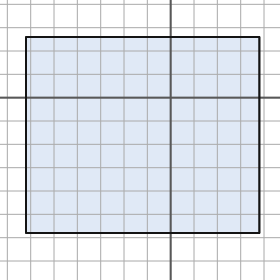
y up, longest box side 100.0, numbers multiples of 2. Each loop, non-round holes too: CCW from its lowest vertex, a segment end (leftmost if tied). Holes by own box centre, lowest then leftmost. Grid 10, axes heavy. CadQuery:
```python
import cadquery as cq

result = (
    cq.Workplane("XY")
    .moveTo(-62.0, -58.0)
    .lineTo(38.0, -58.0)
    .lineTo(38.0, 26.0)
    .lineTo(-62.0, 26.0)
    .close()
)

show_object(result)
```